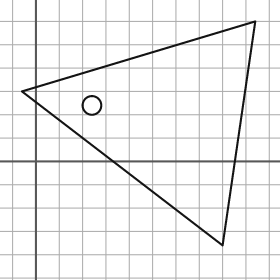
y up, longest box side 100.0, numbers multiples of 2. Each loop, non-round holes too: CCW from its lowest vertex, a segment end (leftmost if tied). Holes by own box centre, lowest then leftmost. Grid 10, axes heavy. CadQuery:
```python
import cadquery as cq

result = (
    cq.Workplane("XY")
    .moveTo(80.0, -36.0)
    .lineTo(94.0, 60.0)
    .lineTo(-6.0, 30.0)
    .close()
    .moveTo(24.0, 24.0)
    .circle(4.0)
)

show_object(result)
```